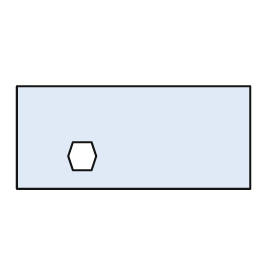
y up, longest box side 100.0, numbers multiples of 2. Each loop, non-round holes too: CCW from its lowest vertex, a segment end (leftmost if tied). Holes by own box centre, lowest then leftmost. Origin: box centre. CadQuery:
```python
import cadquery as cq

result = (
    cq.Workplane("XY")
    .moveTo(-50.0, -22.0)
    .lineTo(50.0, -22.0)
    .lineTo(50.0, 22.0)
    .lineTo(-50.0, 22.0)
    .close()
    .moveTo(-26.0, -14.0)
    .lineTo(-18.0, -14.0)
    .lineTo(-16.0, -8.0)
    .lineTo(-18.0, -2.0)
    .lineTo(-26.0, -2.0)
    .lineTo(-28.0, -8.0)
    .close()
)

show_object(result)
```